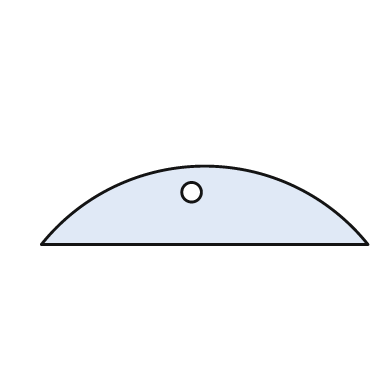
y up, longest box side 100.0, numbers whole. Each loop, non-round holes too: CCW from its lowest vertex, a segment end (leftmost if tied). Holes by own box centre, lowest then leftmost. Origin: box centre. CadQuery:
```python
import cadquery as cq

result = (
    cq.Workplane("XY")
    .moveTo(-50.0, -12.0)
    .lineTo(50.0, -12.0)
    .threePointArc((0.0, 12.0), (-50.0, -12.0))
    .close()
    .moveTo(-4.0, 4.0)
    .circle(3.0)
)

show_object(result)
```